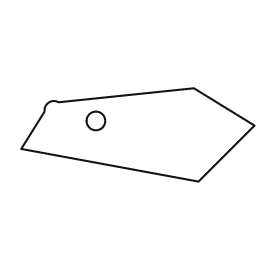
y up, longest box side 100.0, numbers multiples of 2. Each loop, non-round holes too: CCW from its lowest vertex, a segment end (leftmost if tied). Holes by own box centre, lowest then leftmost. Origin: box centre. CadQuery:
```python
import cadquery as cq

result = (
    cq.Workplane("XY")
    .moveTo(26.0, -20.0)
    .lineTo(50.0, 4.0)
    .lineTo(24.0, 20.0)
    .lineTo(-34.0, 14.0)
    .threePointArc((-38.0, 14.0), (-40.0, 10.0))
    .lineTo(-50.0, -6.0)
    .close()
    .moveTo(-18.0, 6.0)
    .circle(4.0)
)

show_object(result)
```